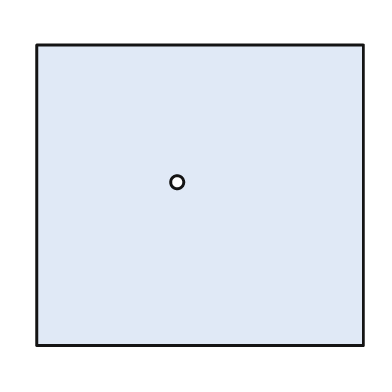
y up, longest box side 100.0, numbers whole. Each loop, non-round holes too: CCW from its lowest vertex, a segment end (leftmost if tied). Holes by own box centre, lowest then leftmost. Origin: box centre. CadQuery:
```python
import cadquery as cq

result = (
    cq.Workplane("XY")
    .moveTo(-50.0, -46.0)
    .lineTo(50.0, -46.0)
    .lineTo(50.0, 46.0)
    .lineTo(-50.0, 46.0)
    .close()
    .moveTo(-7.0, 4.0)
    .circle(2.0)
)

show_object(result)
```